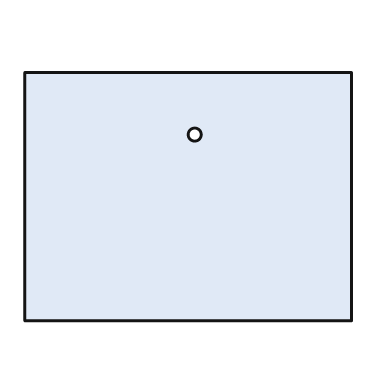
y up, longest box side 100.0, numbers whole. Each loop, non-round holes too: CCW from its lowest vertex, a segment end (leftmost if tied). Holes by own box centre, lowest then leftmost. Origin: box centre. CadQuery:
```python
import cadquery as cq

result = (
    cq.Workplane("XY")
    .moveTo(-50.0, -38.0)
    .lineTo(50.0, -38.0)
    .lineTo(50.0, 38.0)
    .lineTo(-50.0, 38.0)
    .close()
    .moveTo(2.0, 19.0)
    .circle(2.0)
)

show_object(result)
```